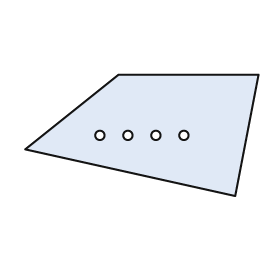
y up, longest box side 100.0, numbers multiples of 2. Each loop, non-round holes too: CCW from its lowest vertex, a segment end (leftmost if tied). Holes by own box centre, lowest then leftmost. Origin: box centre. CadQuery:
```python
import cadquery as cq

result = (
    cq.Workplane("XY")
    .moveTo(40.0, -26.0)
    .lineTo(50.0, 26.0)
    .lineTo(-10.0, 26.0)
    .lineTo(-50.0, -6.0)
    .close()
    .moveTo(-18.0, 0.0)
    .circle(2.0)
    .moveTo(-6.0, 0.0)
    .circle(2.0)
    .moveTo(6.0, 0.0)
    .circle(2.0)
    .moveTo(18.0, 0.0)
    .circle(2.0)
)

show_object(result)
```